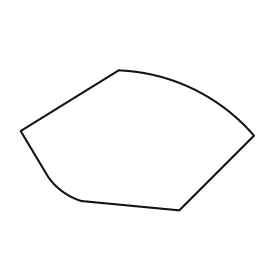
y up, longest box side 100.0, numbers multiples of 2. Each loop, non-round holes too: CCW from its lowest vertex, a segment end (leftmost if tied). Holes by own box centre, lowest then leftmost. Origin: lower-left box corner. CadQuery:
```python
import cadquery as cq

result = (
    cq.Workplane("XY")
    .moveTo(68.0, 0.0)
    .lineTo(100.0, 32.0)
    .threePointArc((74.0, 52.0), (42.0, 60.0))
    .lineTo(0.0, 34.0)
    .lineTo(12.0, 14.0)
    .threePointArc((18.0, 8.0), (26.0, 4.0))
    .close()
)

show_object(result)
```